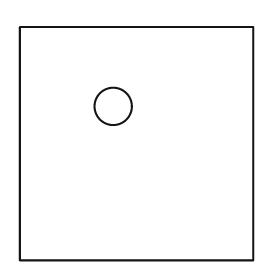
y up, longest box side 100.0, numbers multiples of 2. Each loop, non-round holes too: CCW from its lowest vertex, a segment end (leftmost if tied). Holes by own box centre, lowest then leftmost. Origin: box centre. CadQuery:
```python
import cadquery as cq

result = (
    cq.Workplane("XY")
    .moveTo(-50.0, -50.0)
    .lineTo(50.0, -50.0)
    .lineTo(50.0, 50.0)
    .lineTo(-50.0, 50.0)
    .close()
    .moveTo(-10.0, 16.0)
    .circle(8.0)
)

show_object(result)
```